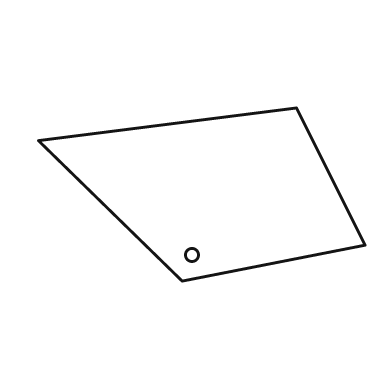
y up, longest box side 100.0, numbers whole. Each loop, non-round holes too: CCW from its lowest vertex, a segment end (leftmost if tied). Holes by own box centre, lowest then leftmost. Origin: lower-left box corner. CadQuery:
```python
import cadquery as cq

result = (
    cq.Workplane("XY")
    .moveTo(44.0, 0.0)
    .lineTo(100.0, 11.0)
    .lineTo(79.0, 53.0)
    .lineTo(0.0, 43.0)
    .close()
    .moveTo(47.0, 8.0)
    .circle(2.0)
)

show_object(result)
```